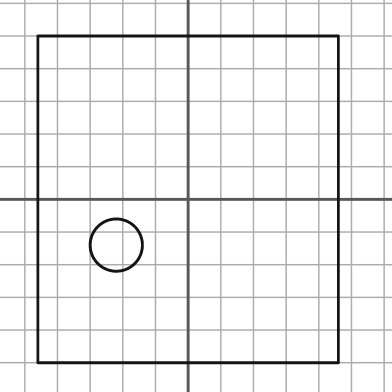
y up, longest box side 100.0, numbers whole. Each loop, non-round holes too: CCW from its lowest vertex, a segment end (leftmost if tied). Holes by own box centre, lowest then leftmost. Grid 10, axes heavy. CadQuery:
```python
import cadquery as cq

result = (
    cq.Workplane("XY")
    .moveTo(-46.0, -50.0)
    .lineTo(46.0, -50.0)
    .lineTo(46.0, 50.0)
    .lineTo(-46.0, 50.0)
    .close()
    .moveTo(-22.0, -14.0)
    .circle(8.0)
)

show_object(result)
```